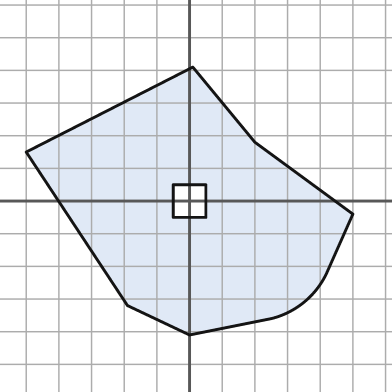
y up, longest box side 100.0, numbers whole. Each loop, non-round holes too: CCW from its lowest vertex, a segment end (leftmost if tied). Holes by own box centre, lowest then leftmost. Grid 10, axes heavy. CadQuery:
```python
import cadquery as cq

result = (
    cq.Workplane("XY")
    .moveTo(0.0, -41.0)
    .lineTo(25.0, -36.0)
    .threePointArc((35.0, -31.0), (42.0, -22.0))
    .lineTo(50.0, -4.0)
    .lineTo(20.0, 18.0)
    .lineTo(1.0, 41.0)
    .lineTo(-50.0, 15.0)
    .lineTo(-19.0, -32.0)
    .close()
    .moveTo(-5.0, -5.0)
    .lineTo(5.0, -5.0)
    .lineTo(5.0, 5.0)
    .lineTo(-5.0, 5.0)
    .close()
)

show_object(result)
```